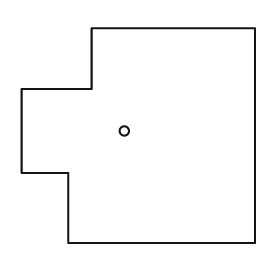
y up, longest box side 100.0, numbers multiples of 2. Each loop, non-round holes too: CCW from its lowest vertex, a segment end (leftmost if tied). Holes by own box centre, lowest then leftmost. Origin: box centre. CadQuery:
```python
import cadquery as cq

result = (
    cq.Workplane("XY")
    .moveTo(-30.0, -46.0)
    .lineTo(50.0, -46.0)
    .lineTo(50.0, 46.0)
    .lineTo(-20.0, 46.0)
    .lineTo(-20.0, 20.0)
    .lineTo(-50.0, 20.0)
    .lineTo(-50.0, -16.0)
    .lineTo(-30.0, -16.0)
    .close()
    .moveTo(-6.0, 2.0)
    .circle(2.0)
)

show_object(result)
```